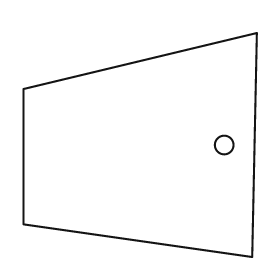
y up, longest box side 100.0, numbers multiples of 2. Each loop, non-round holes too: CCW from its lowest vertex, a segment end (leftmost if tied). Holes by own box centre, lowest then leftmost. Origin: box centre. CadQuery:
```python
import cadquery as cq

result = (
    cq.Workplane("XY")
    .moveTo(48.0, -48.0)
    .lineTo(50.0, 48.0)
    .lineTo(-50.0, 24.0)
    .lineTo(-50.0, -34.0)
    .close()
    .moveTo(36.0, 0.0)
    .circle(4.0)
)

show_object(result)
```